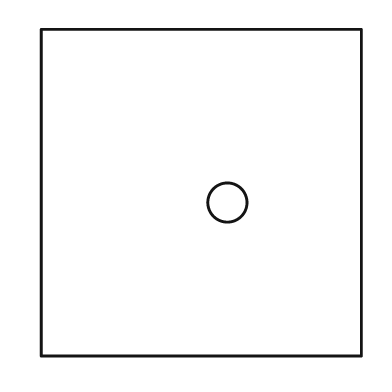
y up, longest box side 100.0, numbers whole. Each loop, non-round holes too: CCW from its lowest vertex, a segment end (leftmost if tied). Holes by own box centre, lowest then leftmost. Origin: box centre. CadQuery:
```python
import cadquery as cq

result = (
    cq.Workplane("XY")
    .moveTo(-49.0, -50.0)
    .lineTo(49.0, -50.0)
    .lineTo(49.0, 50.0)
    .lineTo(-49.0, 50.0)
    .close()
    .moveTo(8.0, -3.0)
    .circle(6.0)
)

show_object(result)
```